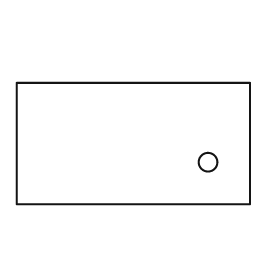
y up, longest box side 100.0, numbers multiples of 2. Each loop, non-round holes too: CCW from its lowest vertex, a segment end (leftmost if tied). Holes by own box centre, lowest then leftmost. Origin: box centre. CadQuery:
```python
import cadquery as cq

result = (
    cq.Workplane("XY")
    .moveTo(-50.0, -26.0)
    .lineTo(50.0, -26.0)
    .lineTo(50.0, 26.0)
    .lineTo(-50.0, 26.0)
    .close()
    .moveTo(32.0, -8.0)
    .circle(4.0)
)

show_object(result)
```